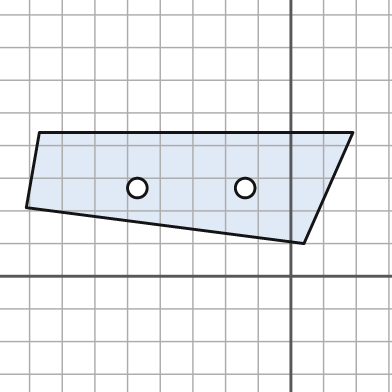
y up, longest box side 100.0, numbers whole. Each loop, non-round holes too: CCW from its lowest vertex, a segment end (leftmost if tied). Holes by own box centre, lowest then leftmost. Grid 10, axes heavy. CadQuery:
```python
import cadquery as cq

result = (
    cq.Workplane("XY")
    .moveTo(4.0, 10.0)
    .lineTo(19.0, 44.0)
    .lineTo(-77.0, 44.0)
    .lineTo(-81.0, 21.0)
    .close()
    .moveTo(-47.0, 27.0)
    .circle(3.0)
    .moveTo(-14.0, 27.0)
    .circle(3.0)
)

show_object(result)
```